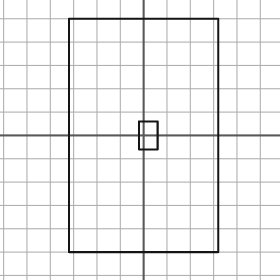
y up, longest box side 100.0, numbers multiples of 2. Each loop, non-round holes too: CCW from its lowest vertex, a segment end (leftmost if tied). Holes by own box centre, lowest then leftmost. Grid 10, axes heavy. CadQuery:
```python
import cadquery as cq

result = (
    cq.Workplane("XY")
    .moveTo(-32.0, -50.0)
    .lineTo(32.0, -50.0)
    .lineTo(32.0, 50.0)
    .lineTo(-32.0, 50.0)
    .close()
    .moveTo(-2.0, -6.0)
    .lineTo(6.0, -6.0)
    .lineTo(6.0, 6.0)
    .lineTo(-2.0, 6.0)
    .close()
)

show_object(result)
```